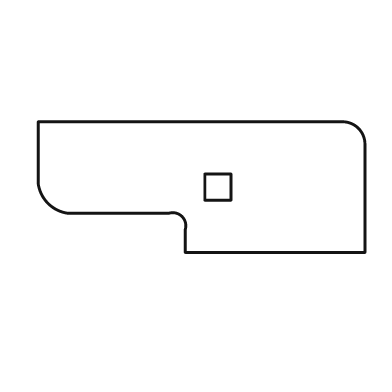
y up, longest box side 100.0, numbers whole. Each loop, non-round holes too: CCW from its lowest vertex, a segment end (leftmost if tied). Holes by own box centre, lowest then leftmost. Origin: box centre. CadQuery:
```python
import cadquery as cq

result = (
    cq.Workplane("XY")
    .moveTo(-5.0, -20.0)
    .lineTo(50.0, -20.0)
    .lineTo(50.0, 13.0)
    .threePointArc((48.0, 18.0), (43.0, 20.0))
    .lineTo(-50.0, 20.0)
    .lineTo(-50.0, 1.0)
    .threePointArc((-47.0, -5.0), (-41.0, -8.0))
    .lineTo(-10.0, -8.0)
    .threePointArc((-6.0, -9.0), (-5.0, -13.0))
    .close()
    .moveTo(1.0, -4.0)
    .lineTo(9.0, -4.0)
    .lineTo(9.0, 4.0)
    .lineTo(1.0, 4.0)
    .close()
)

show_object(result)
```